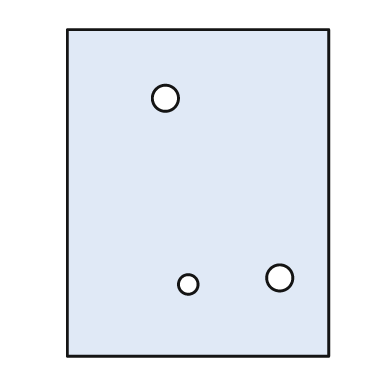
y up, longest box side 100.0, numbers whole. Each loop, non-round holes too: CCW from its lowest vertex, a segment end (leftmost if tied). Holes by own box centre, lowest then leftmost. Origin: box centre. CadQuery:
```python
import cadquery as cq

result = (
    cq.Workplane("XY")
    .moveTo(-40.0, -50.0)
    .lineTo(40.0, -50.0)
    .lineTo(40.0, 50.0)
    .lineTo(-40.0, 50.0)
    .close()
    .moveTo(-3.0, -28.0)
    .circle(3.0)
    .moveTo(25.0, -26.0)
    .circle(4.0)
    .moveTo(-10.0, 29.0)
    .circle(4.0)
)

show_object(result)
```